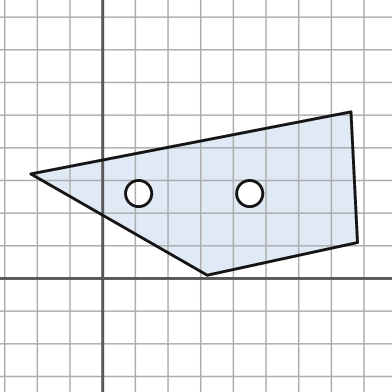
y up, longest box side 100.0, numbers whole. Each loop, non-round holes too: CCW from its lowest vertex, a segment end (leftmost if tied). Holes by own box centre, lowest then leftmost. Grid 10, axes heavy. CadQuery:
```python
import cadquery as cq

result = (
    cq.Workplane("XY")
    .moveTo(32.0, 1.0)
    .lineTo(78.0, 11.0)
    .lineTo(76.0, 51.0)
    .lineTo(-22.0, 32.0)
    .close()
    .moveTo(11.0, 26.0)
    .circle(4.0)
    .moveTo(45.0, 26.0)
    .circle(4.0)
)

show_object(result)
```